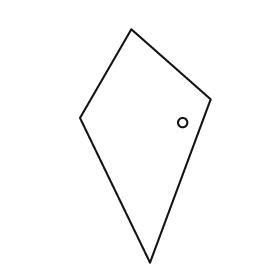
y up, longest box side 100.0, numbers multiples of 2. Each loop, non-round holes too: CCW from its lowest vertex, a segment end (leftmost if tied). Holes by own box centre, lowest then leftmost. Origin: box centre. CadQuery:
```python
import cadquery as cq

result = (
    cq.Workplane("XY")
    .moveTo(2.0, -50.0)
    .lineTo(28.0, 20.0)
    .lineTo(-6.0, 50.0)
    .lineTo(-28.0, 12.0)
    .close()
    .moveTo(16.0, 10.0)
    .circle(2.0)
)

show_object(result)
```